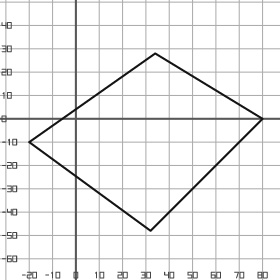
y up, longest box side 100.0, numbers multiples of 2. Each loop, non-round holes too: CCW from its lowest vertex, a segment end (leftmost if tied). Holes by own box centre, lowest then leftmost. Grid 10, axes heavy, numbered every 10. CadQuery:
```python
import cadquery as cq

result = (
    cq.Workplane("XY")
    .moveTo(32.0, -48.0)
    .lineTo(80.0, 0.0)
    .lineTo(34.0, 28.0)
    .lineTo(-20.0, -10.0)
    .close()
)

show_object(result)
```